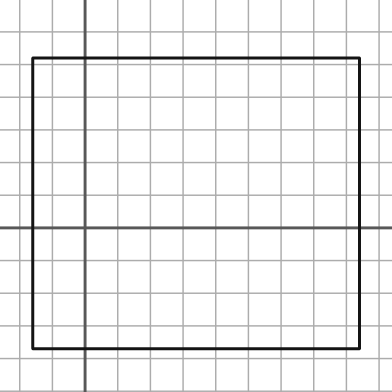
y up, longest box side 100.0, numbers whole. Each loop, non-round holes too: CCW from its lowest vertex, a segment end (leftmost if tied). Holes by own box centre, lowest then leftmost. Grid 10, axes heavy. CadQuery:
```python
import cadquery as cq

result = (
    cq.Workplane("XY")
    .moveTo(-16.0, -37.0)
    .lineTo(84.0, -37.0)
    .lineTo(84.0, 52.0)
    .lineTo(-16.0, 52.0)
    .close()
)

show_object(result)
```